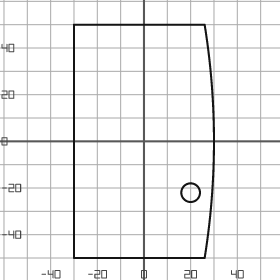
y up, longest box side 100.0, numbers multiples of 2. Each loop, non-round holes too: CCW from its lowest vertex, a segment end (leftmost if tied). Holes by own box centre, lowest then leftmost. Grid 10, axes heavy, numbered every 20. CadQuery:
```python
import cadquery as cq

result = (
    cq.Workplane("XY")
    .moveTo(-30.0, -50.0)
    .lineTo(26.0, -50.0)
    .threePointArc((30.0, 0.0), (26.0, 50.0))
    .lineTo(-30.0, 50.0)
    .close()
    .moveTo(20.0, -22.0)
    .circle(4.0)
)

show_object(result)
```